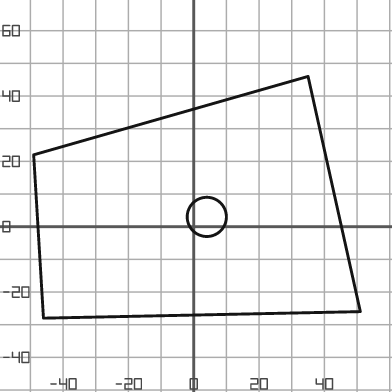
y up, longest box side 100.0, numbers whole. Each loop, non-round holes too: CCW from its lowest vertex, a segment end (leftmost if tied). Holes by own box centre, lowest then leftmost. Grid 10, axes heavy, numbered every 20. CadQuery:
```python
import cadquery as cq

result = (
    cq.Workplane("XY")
    .moveTo(-46.0, -28.0)
    .lineTo(51.0, -26.0)
    .lineTo(35.0, 46.0)
    .lineTo(-49.0, 22.0)
    .close()
    .moveTo(4.0, 3.0)
    .circle(6.0)
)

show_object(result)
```